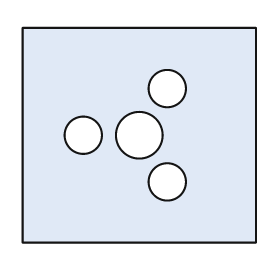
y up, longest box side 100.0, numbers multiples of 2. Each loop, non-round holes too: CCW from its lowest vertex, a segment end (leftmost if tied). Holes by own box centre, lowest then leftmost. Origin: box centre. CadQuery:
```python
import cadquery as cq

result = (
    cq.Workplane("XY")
    .moveTo(-50.0, -46.0)
    .lineTo(50.0, -46.0)
    .lineTo(50.0, 46.0)
    .lineTo(-50.0, 46.0)
    .close()
    .moveTo(12.0, -20.0)
    .circle(8.0)
    .moveTo(-24.0, 0.0)
    .circle(8.0)
    .moveTo(0.0, 0.0)
    .circle(10.0)
    .moveTo(12.0, 20.0)
    .circle(8.0)
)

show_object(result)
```